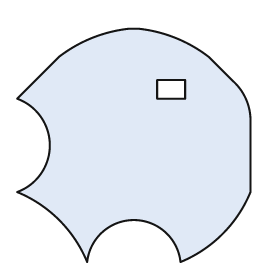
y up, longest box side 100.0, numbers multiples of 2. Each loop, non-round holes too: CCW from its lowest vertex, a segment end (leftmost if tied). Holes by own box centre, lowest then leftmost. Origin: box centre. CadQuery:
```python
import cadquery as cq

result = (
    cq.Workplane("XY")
    .moveTo(-20.0, -50.0)
    .threePointArc((0.0, -32.0), (20.0, -50.0))
    .threePointArc((38.0, -38.0), (50.0, -20.0))
    .lineTo(50.0, 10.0)
    .threePointArc((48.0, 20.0), (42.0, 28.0))
    .lineTo(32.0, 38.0)
    .threePointArc((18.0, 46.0), (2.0, 50.0))
    .lineTo(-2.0, 50.0)
    .threePointArc((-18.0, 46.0), (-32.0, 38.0))
    .lineTo(-50.0, 20.0)
    .threePointArc((-36.0, 0.0), (-50.0, -20.0))
    .threePointArc((-32.0, -32.0), (-20.0, -50.0))
    .close()
    .moveTo(10.0, 20.0)
    .lineTo(22.0, 20.0)
    .lineTo(22.0, 28.0)
    .lineTo(10.0, 28.0)
    .close()
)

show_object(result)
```